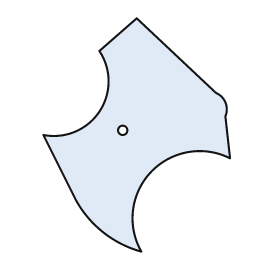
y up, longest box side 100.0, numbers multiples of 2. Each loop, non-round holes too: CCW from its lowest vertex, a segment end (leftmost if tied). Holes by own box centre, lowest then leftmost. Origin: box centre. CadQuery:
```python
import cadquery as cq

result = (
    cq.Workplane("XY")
    .moveTo(2.0, -50.0)
    .threePointArc((6.0, -16.0), (40.0, -10.0))
    .lineTo(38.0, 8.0)
    .threePointArc((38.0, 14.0), (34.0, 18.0))
    .lineTo(0.0, 50.0)
    .lineTo(-16.0, 36.0)
    .threePointArc((-16.0, 10.0), (-40.0, 0.0))
    .lineTo(-26.0, -28.0)
    .threePointArc((-14.0, -42.0), (2.0, -50.0))
    .close()
    .moveTo(-6.0, 2.0)
    .circle(2.0)
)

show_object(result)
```